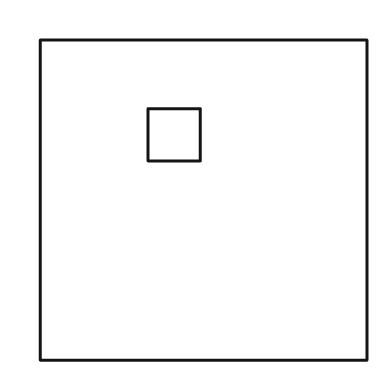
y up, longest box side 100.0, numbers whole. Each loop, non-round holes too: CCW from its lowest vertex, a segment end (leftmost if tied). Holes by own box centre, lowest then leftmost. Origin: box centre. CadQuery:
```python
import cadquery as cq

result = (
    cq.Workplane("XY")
    .moveTo(-50.0, -49.0)
    .lineTo(50.0, -49.0)
    .lineTo(50.0, 49.0)
    .lineTo(-50.0, 49.0)
    .close()
    .moveTo(-17.0, 12.0)
    .lineTo(-1.0, 12.0)
    .lineTo(-1.0, 28.0)
    .lineTo(-17.0, 28.0)
    .close()
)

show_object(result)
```